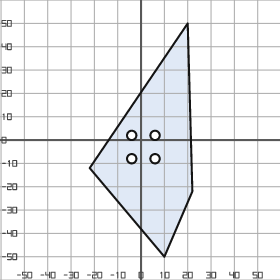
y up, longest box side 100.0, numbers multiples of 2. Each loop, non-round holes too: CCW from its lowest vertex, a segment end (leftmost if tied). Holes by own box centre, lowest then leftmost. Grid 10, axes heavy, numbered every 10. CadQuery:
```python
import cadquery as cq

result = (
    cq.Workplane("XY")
    .moveTo(10.0, -50.0)
    .lineTo(22.0, -22.0)
    .lineTo(20.0, 50.0)
    .lineTo(-22.0, -12.0)
    .close()
    .moveTo(-4.0, -8.0)
    .circle(2.0)
    .moveTo(6.0, -8.0)
    .circle(2.0)
    .moveTo(-4.0, 2.0)
    .circle(2.0)
    .moveTo(6.0, 2.0)
    .circle(2.0)
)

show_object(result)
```